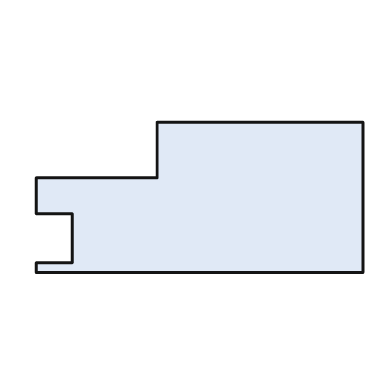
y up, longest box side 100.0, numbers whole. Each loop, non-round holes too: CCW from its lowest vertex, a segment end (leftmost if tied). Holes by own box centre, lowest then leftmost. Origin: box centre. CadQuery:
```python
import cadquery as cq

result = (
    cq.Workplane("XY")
    .moveTo(-50.0, -23.0)
    .lineTo(50.0, -23.0)
    .lineTo(50.0, 23.0)
    .lineTo(-13.0, 23.0)
    .lineTo(-13.0, 6.0)
    .lineTo(-50.0, 6.0)
    .lineTo(-50.0, -5.0)
    .lineTo(-39.0, -5.0)
    .lineTo(-39.0, -20.0)
    .lineTo(-50.0, -20.0)
    .close()
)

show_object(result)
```